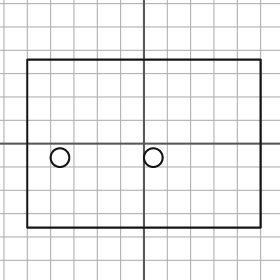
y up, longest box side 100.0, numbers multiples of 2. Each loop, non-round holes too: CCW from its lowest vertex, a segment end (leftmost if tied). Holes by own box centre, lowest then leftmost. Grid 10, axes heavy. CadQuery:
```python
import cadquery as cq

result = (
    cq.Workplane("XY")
    .moveTo(-50.0, -36.0)
    .lineTo(50.0, -36.0)
    .lineTo(50.0, 36.0)
    .lineTo(-50.0, 36.0)
    .close()
    .moveTo(-36.0, -6.0)
    .circle(4.0)
    .moveTo(4.0, -6.0)
    .circle(4.0)
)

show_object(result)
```